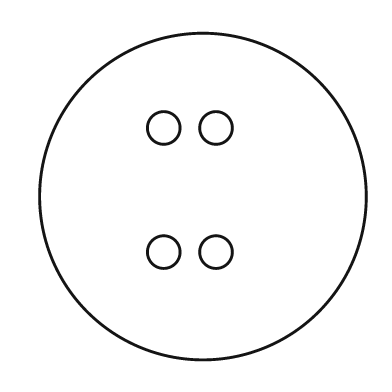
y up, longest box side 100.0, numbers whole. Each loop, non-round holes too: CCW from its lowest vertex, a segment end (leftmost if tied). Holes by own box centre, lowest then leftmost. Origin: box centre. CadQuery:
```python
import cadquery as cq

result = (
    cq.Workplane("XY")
    .moveTo(0.0, 0.0)
    .circle(50.0)
    .moveTo(-12.0, -17.0)
    .circle(5.0)
    .moveTo(4.0, -17.0)
    .circle(5.0)
    .moveTo(-12.0, 21.0)
    .circle(5.0)
    .moveTo(4.0, 21.0)
    .circle(5.0)
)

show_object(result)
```